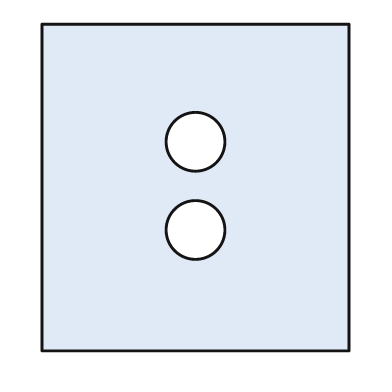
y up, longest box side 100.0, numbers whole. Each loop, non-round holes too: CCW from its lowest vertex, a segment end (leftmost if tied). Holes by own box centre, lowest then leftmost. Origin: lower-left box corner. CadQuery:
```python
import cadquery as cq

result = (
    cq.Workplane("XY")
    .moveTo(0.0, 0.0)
    .lineTo(94.0, 0.0)
    .lineTo(94.0, 100.0)
    .lineTo(0.0, 100.0)
    .close()
    .moveTo(47.0, 37.0)
    .circle(9.0)
    .moveTo(47.0, 64.0)
    .circle(9.0)
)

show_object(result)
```